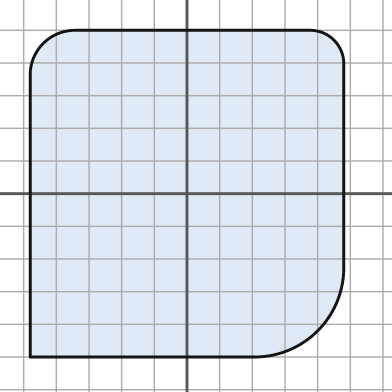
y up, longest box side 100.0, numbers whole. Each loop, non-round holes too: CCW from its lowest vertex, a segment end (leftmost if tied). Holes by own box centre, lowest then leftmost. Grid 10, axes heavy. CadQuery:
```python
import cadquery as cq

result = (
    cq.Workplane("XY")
    .moveTo(-48.0, -50.0)
    .lineTo(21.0, -50.0)
    .threePointArc((40.0, -42.0), (48.0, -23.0))
    .lineTo(48.0, 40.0)
    .threePointArc((45.0, 47.0), (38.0, 50.0))
    .lineTo(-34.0, 50.0)
    .threePointArc((-44.0, 46.0), (-48.0, 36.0))
    .close()
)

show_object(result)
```